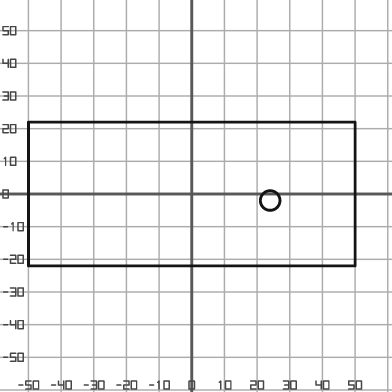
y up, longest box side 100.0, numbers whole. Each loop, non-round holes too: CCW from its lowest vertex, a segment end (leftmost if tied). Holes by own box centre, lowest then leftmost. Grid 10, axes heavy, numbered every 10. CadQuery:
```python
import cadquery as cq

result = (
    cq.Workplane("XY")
    .moveTo(-50.0, -22.0)
    .lineTo(50.0, -22.0)
    .lineTo(50.0, 22.0)
    .lineTo(-50.0, 22.0)
    .close()
    .moveTo(24.0, -2.0)
    .circle(3.0)
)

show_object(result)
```